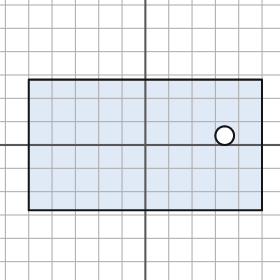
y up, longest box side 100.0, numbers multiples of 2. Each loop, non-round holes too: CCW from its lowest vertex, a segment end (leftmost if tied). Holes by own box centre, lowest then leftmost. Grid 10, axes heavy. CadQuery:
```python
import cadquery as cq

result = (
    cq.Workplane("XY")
    .moveTo(-50.0, -28.0)
    .lineTo(50.0, -28.0)
    .lineTo(50.0, 28.0)
    .lineTo(-50.0, 28.0)
    .close()
    .moveTo(34.0, 4.0)
    .circle(4.0)
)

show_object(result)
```